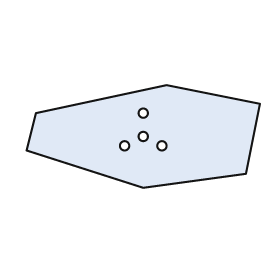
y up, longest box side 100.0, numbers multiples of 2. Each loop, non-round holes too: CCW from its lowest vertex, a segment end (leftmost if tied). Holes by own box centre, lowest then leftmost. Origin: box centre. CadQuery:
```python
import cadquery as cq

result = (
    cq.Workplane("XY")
    .moveTo(0.0, -22.0)
    .lineTo(44.0, -16.0)
    .lineTo(50.0, 14.0)
    .lineTo(10.0, 22.0)
    .lineTo(-46.0, 10.0)
    .lineTo(-50.0, -6.0)
    .close()
    .moveTo(-8.0, -4.0)
    .circle(2.0)
    .moveTo(8.0, -4.0)
    .circle(2.0)
    .moveTo(0.0, 0.0)
    .circle(2.0)
    .moveTo(0.0, 10.0)
    .circle(2.0)
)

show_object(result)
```